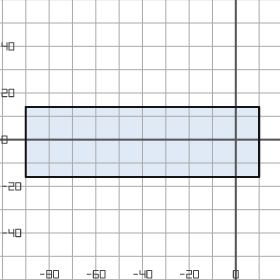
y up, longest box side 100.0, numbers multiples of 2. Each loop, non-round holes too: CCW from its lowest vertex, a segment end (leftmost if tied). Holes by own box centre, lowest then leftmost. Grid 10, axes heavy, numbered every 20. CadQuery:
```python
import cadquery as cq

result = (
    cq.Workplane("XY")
    .moveTo(-90.0, -16.0)
    .lineTo(10.0, -16.0)
    .lineTo(10.0, 14.0)
    .lineTo(-90.0, 14.0)
    .close()
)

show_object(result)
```